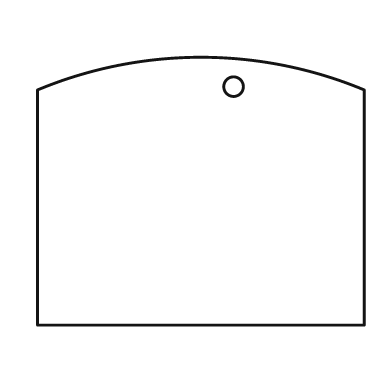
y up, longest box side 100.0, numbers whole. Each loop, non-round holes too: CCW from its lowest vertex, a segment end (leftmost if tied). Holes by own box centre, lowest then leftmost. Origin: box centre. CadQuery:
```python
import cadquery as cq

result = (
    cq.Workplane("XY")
    .moveTo(-50.0, -41.0)
    .lineTo(50.0, -41.0)
    .lineTo(50.0, 31.0)
    .threePointArc((0.0, 41.0), (-50.0, 31.0))
    .close()
    .moveTo(10.0, 32.0)
    .circle(3.0)
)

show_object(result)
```